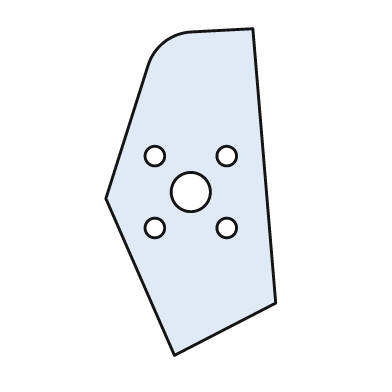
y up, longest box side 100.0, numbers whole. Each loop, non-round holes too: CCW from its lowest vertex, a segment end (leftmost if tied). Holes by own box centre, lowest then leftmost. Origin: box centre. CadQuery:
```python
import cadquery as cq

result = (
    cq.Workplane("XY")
    .moveTo(-5.0, -50.0)
    .lineTo(26.0, -34.0)
    .lineTo(19.0, 50.0)
    .lineTo(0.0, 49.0)
    .threePointArc((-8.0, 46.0), (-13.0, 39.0))
    .lineTo(-26.0, -2.0)
    .close()
    .moveTo(-11.0, -11.0)
    .circle(3.0)
    .moveTo(11.0, -11.0)
    .circle(3.0)
    .moveTo(0.0, 0.0)
    .circle(6.0)
    .moveTo(-11.0, 11.0)
    .circle(3.0)
    .moveTo(11.0, 11.0)
    .circle(3.0)
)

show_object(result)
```